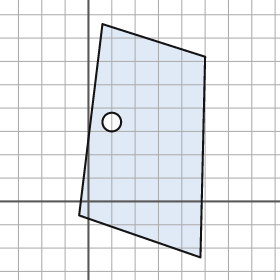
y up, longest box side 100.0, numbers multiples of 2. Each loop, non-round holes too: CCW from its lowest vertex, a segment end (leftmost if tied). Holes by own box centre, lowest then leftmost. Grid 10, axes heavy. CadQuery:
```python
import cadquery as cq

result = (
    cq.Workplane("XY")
    .moveTo(48.0, -24.0)
    .lineTo(50.0, 62.0)
    .lineTo(6.0, 76.0)
    .lineTo(-4.0, -6.0)
    .close()
    .moveTo(10.0, 34.0)
    .circle(4.0)
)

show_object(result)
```